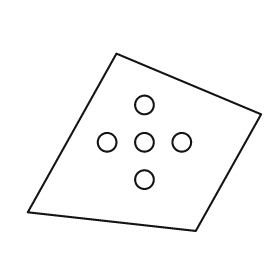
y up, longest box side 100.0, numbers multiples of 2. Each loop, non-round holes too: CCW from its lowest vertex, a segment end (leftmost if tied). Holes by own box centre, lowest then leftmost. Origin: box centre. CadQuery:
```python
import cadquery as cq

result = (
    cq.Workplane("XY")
    .moveTo(22.0, -38.0)
    .lineTo(50.0, 12.0)
    .lineTo(-12.0, 38.0)
    .lineTo(-50.0, -30.0)
    .close()
    .moveTo(0.0, -16.0)
    .circle(4.0)
    .moveTo(-16.0, 0.0)
    .circle(4.0)
    .moveTo(0.0, 0.0)
    .circle(4.0)
    .moveTo(16.0, 0.0)
    .circle(4.0)
    .moveTo(0.0, 16.0)
    .circle(4.0)
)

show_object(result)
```